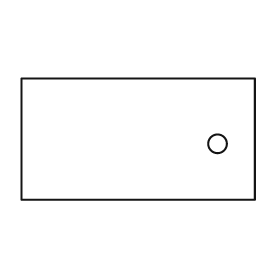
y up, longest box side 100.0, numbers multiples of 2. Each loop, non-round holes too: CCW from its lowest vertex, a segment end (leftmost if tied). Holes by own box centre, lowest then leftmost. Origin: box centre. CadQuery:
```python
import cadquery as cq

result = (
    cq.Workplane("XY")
    .moveTo(-50.0, -26.0)
    .lineTo(50.0, -26.0)
    .lineTo(50.0, 26.0)
    .lineTo(-50.0, 26.0)
    .close()
    .moveTo(34.0, -2.0)
    .circle(4.0)
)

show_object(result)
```